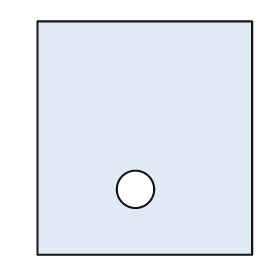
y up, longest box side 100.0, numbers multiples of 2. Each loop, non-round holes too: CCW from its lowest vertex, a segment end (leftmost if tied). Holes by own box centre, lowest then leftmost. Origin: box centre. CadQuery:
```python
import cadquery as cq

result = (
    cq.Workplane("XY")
    .moveTo(-46.0, -50.0)
    .lineTo(46.0, -50.0)
    .lineTo(46.0, 50.0)
    .lineTo(-46.0, 50.0)
    .close()
    .moveTo(-4.0, -22.0)
    .circle(8.0)
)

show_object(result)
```